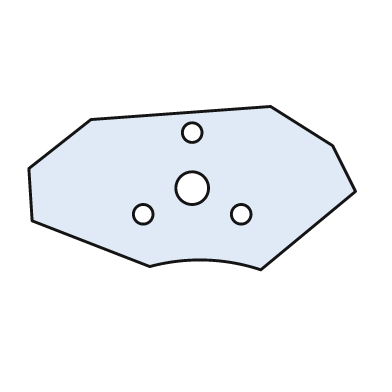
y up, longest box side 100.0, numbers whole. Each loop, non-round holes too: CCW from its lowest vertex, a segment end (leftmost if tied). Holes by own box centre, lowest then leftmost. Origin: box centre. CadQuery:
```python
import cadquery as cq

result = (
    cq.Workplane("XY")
    .moveTo(21.0, -25.0)
    .lineTo(50.0, -1.0)
    .lineTo(43.0, 13.0)
    .lineTo(24.0, 25.0)
    .lineTo(-31.0, 21.0)
    .lineTo(-50.0, 6.0)
    .lineTo(-49.0, -10.0)
    .lineTo(-13.0, -24.0)
    .threePointArc((4.0, -22.0), (21.0, -25.0))
    .close()
    .moveTo(-15.0, -8.0)
    .circle(3.0)
    .moveTo(15.0, -8.0)
    .circle(3.0)
    .moveTo(0.0, 0.0)
    .circle(5.0)
    .moveTo(0.0, 17.0)
    .circle(3.0)
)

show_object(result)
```